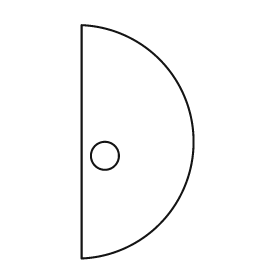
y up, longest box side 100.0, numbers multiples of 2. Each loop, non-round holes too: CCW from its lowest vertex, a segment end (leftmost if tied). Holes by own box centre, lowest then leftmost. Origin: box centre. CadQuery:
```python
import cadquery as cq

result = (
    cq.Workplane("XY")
    .moveTo(-24.0, -50.0)
    .threePointArc((24.0, 0.0), (-24.0, 50.0))
    .close()
    .moveTo(-14.0, -6.0)
    .circle(6.0)
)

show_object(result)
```